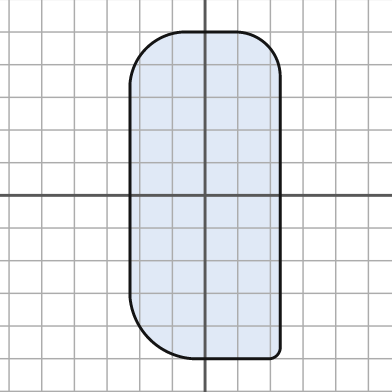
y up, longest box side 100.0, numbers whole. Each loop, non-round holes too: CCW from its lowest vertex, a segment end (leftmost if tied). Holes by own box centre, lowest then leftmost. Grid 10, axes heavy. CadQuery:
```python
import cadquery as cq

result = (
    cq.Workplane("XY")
    .moveTo(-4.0, -50.0)
    .lineTo(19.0, -50.0)
    .threePointArc((22.0, -49.0), (23.0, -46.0))
    .lineTo(23.0, 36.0)
    .threePointArc((19.0, 46.0), (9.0, 50.0))
    .lineTo(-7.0, 50.0)
    .threePointArc((-18.0, 45.0), (-23.0, 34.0))
    .lineTo(-23.0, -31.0)
    .threePointArc((-17.0, -44.0), (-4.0, -50.0))
    .close()
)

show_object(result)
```